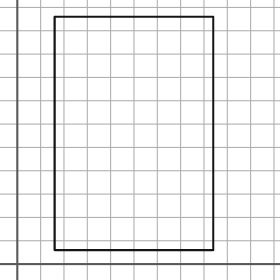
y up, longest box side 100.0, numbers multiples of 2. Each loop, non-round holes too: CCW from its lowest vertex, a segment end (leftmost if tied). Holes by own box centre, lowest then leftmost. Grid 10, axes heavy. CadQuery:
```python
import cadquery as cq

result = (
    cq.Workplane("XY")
    .moveTo(16.0, 6.0)
    .lineTo(84.0, 6.0)
    .lineTo(84.0, 106.0)
    .lineTo(16.0, 106.0)
    .close()
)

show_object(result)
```